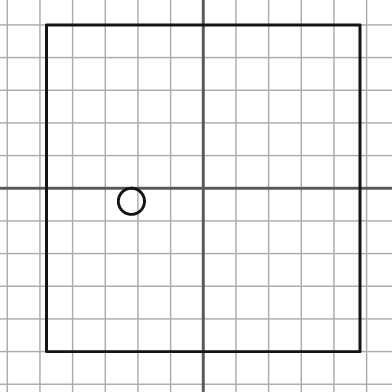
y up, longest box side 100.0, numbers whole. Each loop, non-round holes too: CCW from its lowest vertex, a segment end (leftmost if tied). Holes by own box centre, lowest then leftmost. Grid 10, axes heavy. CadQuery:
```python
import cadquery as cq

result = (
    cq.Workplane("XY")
    .moveTo(-48.0, -50.0)
    .lineTo(48.0, -50.0)
    .lineTo(48.0, 50.0)
    .lineTo(-48.0, 50.0)
    .close()
    .moveTo(-22.0, -4.0)
    .circle(4.0)
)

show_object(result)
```